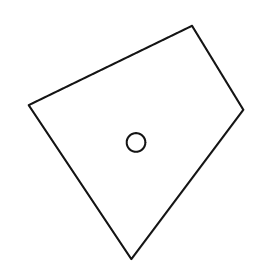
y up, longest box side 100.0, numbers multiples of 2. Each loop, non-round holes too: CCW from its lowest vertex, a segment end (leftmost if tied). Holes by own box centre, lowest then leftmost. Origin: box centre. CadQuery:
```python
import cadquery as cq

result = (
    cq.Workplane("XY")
    .moveTo(-2.0, -50.0)
    .lineTo(46.0, 14.0)
    .lineTo(24.0, 50.0)
    .lineTo(-46.0, 16.0)
    .close()
    .moveTo(0.0, 0.0)
    .circle(4.0)
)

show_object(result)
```